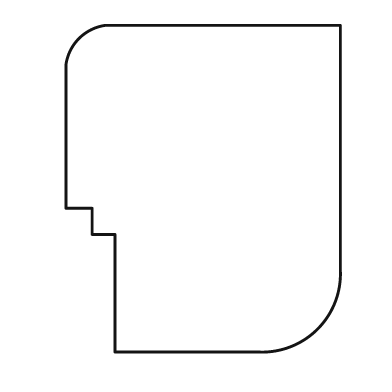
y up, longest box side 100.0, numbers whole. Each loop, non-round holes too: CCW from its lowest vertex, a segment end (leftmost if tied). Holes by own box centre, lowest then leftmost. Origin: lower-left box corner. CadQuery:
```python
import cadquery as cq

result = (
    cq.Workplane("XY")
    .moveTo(15.0, 0.0)
    .lineTo(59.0, 0.0)
    .threePointArc((77.0, 7.0), (84.0, 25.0))
    .lineTo(84.0, 100.0)
    .lineTo(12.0, 100.0)
    .threePointArc((4.0, 96.0), (0.0, 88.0))
    .lineTo(0.0, 44.0)
    .lineTo(8.0, 44.0)
    .lineTo(8.0, 36.0)
    .lineTo(15.0, 36.0)
    .close()
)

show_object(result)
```